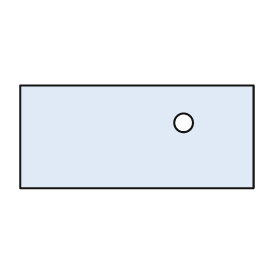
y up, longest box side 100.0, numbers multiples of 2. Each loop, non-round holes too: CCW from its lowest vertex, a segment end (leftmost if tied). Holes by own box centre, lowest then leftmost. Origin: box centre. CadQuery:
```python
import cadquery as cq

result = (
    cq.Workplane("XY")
    .moveTo(-50.0, -22.0)
    .lineTo(50.0, -22.0)
    .lineTo(50.0, 22.0)
    .lineTo(-50.0, 22.0)
    .close()
    .moveTo(20.0, 6.0)
    .circle(4.0)
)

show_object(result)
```